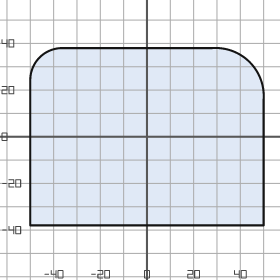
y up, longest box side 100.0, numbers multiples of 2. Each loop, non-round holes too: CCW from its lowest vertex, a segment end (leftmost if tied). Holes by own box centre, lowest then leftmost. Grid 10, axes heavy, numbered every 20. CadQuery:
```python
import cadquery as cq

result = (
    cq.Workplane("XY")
    .moveTo(-50.0, -38.0)
    .lineTo(50.0, -38.0)
    .lineTo(50.0, 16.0)
    .threePointArc((44.0, 32.0), (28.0, 38.0))
    .lineTo(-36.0, 38.0)
    .threePointArc((-46.0, 34.0), (-50.0, 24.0))
    .close()
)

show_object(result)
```